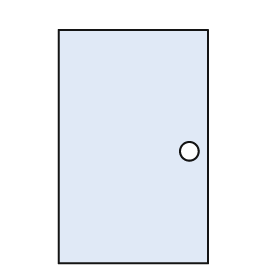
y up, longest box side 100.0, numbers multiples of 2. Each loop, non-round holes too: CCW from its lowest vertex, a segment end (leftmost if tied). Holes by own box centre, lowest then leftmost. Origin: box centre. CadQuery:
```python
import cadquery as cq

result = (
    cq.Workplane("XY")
    .moveTo(-32.0, -50.0)
    .lineTo(32.0, -50.0)
    .lineTo(32.0, 50.0)
    .lineTo(-32.0, 50.0)
    .close()
    .moveTo(24.0, -2.0)
    .circle(4.0)
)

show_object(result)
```